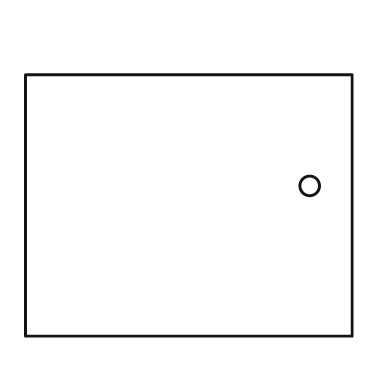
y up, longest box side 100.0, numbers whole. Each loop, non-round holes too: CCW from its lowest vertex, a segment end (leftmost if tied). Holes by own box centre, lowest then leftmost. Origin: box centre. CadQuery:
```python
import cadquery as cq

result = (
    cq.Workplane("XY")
    .moveTo(-50.0, -40.0)
    .lineTo(50.0, -40.0)
    .lineTo(50.0, 40.0)
    .lineTo(-50.0, 40.0)
    .close()
    .moveTo(37.0, 6.0)
    .circle(3.0)
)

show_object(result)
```